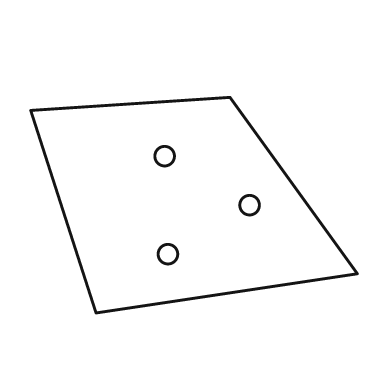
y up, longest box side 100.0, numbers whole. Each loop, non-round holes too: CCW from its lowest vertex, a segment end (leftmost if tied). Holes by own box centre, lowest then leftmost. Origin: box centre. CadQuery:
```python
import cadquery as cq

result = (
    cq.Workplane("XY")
    .moveTo(-30.0, -33.0)
    .lineTo(50.0, -21.0)
    .lineTo(11.0, 33.0)
    .lineTo(-50.0, 29.0)
    .close()
    .moveTo(-8.0, -15.0)
    .circle(3.0)
    .moveTo(17.0, 0.0)
    .circle(3.0)
    .moveTo(-9.0, 15.0)
    .circle(3.0)
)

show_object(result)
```